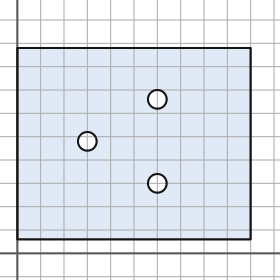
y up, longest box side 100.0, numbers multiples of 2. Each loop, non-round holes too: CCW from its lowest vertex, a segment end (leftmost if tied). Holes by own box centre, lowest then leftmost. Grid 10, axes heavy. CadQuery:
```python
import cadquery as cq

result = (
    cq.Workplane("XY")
    .moveTo(0.0, 6.0)
    .lineTo(100.0, 6.0)
    .lineTo(100.0, 88.0)
    .lineTo(0.0, 88.0)
    .close()
    .moveTo(60.0, 30.0)
    .circle(4.0)
    .moveTo(30.0, 48.0)
    .circle(4.0)
    .moveTo(60.0, 66.0)
    .circle(4.0)
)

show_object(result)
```